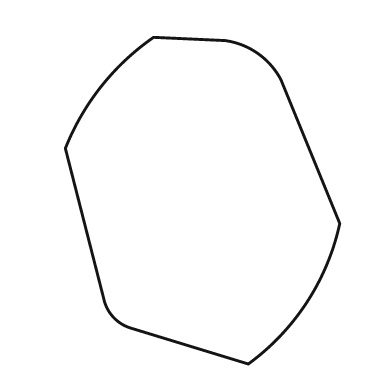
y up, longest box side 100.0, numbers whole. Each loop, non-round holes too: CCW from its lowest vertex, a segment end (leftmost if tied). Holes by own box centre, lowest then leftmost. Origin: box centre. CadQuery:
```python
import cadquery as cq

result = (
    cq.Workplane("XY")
    .moveTo(14.0, -50.0)
    .threePointArc((32.0, -31.0), (42.0, -7.0))
    .lineTo(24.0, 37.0)
    .threePointArc((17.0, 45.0), (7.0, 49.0))
    .lineTo(-15.0, 50.0)
    .threePointArc((-31.0, 35.0), (-42.0, 16.0))
    .lineTo(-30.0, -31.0)
    .threePointArc((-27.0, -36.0), (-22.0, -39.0))
    .close()
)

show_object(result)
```